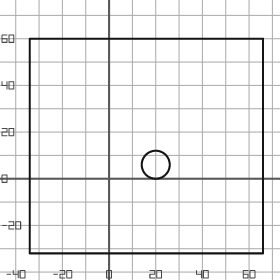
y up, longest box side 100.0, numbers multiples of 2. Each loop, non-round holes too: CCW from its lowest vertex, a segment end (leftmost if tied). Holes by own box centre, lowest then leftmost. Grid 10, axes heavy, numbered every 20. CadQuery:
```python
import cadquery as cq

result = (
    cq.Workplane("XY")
    .moveTo(-34.0, -32.0)
    .lineTo(66.0, -32.0)
    .lineTo(66.0, 60.0)
    .lineTo(-34.0, 60.0)
    .close()
    .moveTo(20.0, 6.0)
    .circle(6.0)
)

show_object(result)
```